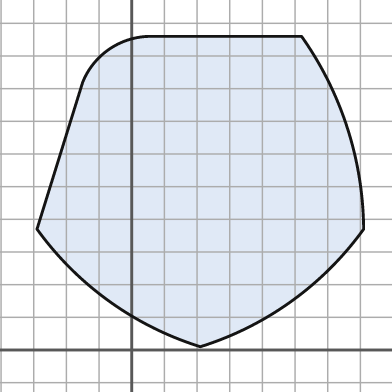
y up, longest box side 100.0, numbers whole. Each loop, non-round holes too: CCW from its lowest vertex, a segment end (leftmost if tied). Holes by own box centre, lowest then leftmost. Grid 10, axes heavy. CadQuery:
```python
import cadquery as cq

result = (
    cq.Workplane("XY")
    .moveTo(21.0, 1.0)
    .threePointArc((49.0, 15.0), (71.0, 37.0))
    .threePointArc((66.0, 68.0), (52.0, 96.0))
    .lineTo(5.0, 96.0)
    .threePointArc((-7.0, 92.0), (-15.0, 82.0))
    .lineTo(-29.0, 37.0)
    .threePointArc((-7.0, 15.0), (21.0, 1.0))
    .close()
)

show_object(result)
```